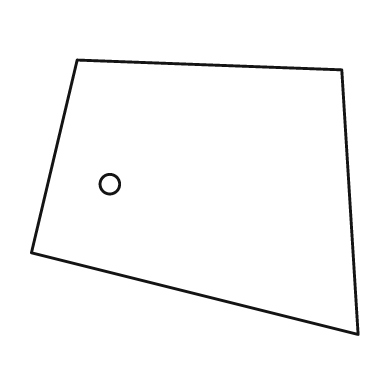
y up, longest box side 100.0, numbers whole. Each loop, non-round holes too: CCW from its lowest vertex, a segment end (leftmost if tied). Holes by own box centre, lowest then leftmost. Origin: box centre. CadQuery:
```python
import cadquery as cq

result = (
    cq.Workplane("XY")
    .moveTo(50.0, -42.0)
    .lineTo(45.0, 39.0)
    .lineTo(-36.0, 42.0)
    .lineTo(-50.0, -17.0)
    .close()
    .moveTo(-26.0, 4.0)
    .circle(3.0)
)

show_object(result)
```